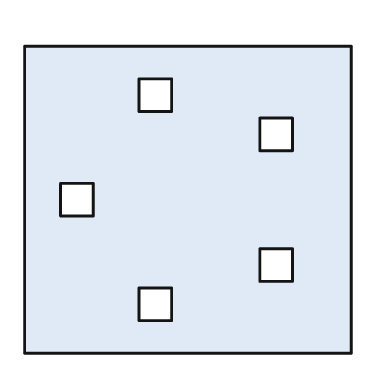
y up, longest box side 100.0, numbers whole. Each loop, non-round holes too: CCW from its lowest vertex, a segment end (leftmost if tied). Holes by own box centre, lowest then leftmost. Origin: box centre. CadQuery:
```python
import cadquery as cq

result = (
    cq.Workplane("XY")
    .moveTo(-50.0, -47.0)
    .lineTo(50.0, -47.0)
    .lineTo(50.0, 47.0)
    .lineTo(-50.0, 47.0)
    .close()
    .moveTo(-15.0, -37.0)
    .lineTo(-5.0, -37.0)
    .lineTo(-5.0, -27.0)
    .lineTo(-15.0, -27.0)
    .close()
    .moveTo(22.0, -25.0)
    .lineTo(32.0, -25.0)
    .lineTo(32.0, -15.0)
    .lineTo(22.0, -15.0)
    .close()
    .moveTo(-39.0, -5.0)
    .lineTo(-29.0, -5.0)
    .lineTo(-29.0, 5.0)
    .lineTo(-39.0, 5.0)
    .close()
    .moveTo(22.0, 15.0)
    .lineTo(32.0, 15.0)
    .lineTo(32.0, 25.0)
    .lineTo(22.0, 25.0)
    .close()
    .moveTo(-15.0, 27.0)
    .lineTo(-5.0, 27.0)
    .lineTo(-5.0, 37.0)
    .lineTo(-15.0, 37.0)
    .close()
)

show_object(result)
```